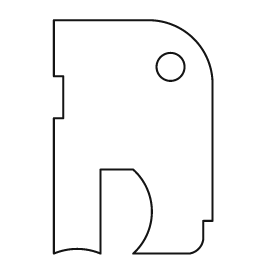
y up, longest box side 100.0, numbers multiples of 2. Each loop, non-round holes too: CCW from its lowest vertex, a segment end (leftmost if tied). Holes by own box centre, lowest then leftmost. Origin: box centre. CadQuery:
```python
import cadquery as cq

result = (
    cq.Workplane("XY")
    .moveTo(-34.0, -50.0)
    .threePointArc((-24.0, -48.0), (-14.0, -50.0))
    .lineTo(-14.0, -14.0)
    .lineTo(0.0, -14.0)
    .threePointArc((8.0, -32.0), (0.0, -50.0))
    .lineTo(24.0, -50.0)
    .threePointArc((28.0, -48.0), (30.0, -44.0))
    .lineTo(30.0, -36.0)
    .lineTo(34.0, -36.0)
    .lineTo(34.0, 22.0)
    .threePointArc((26.0, 42.0), (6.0, 50.0))
    .lineTo(-34.0, 50.0)
    .lineTo(-34.0, 26.0)
    .lineTo(-30.0, 26.0)
    .lineTo(-30.0, 8.0)
    .lineTo(-34.0, 8.0)
    .close()
    .moveTo(16.0, 30.0)
    .circle(6.0)
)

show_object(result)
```